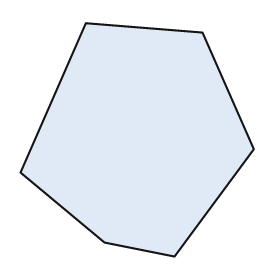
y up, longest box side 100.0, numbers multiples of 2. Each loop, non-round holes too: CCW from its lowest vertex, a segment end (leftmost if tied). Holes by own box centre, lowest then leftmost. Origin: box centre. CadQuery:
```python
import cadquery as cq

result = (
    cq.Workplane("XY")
    .moveTo(16.0, -50.0)
    .lineTo(50.0, -4.0)
    .lineTo(28.0, 46.0)
    .lineTo(-22.0, 50.0)
    .lineTo(-50.0, -14.0)
    .lineTo(-14.0, -44.0)
    .close()
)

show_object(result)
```